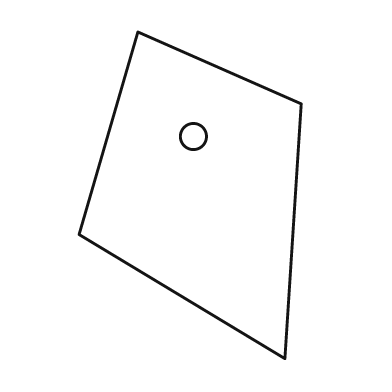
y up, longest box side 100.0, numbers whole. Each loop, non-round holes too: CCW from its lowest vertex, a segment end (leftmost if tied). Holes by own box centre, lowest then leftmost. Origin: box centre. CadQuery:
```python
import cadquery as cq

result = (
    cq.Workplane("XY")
    .moveTo(29.0, -50.0)
    .lineTo(34.0, 28.0)
    .lineTo(-16.0, 50.0)
    .lineTo(-34.0, -12.0)
    .close()
    .moveTo(1.0, 18.0)
    .circle(4.0)
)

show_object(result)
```